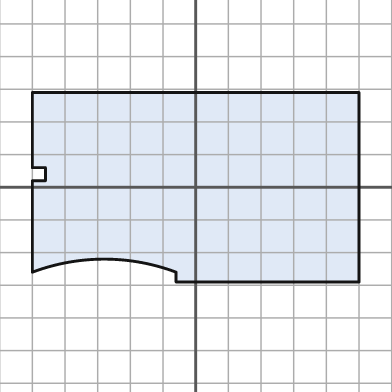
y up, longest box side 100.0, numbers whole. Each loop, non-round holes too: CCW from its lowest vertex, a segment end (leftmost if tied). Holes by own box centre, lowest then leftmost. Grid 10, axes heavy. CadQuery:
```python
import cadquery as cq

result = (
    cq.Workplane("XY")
    .moveTo(-6.0, -29.0)
    .lineTo(50.0, -29.0)
    .lineTo(50.0, 29.0)
    .lineTo(-50.0, 29.0)
    .lineTo(-50.0, 6.0)
    .lineTo(-46.0, 6.0)
    .lineTo(-46.0, 2.0)
    .lineTo(-50.0, 2.0)
    .lineTo(-50.0, -26.0)
    .threePointArc((-28.0, -22.0), (-6.0, -26.0))
    .close()
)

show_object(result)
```